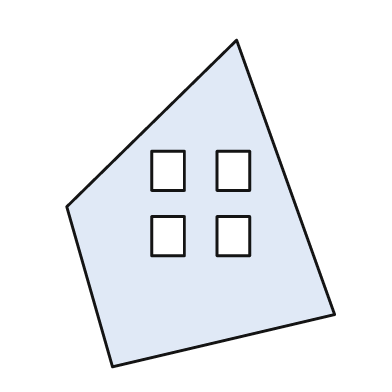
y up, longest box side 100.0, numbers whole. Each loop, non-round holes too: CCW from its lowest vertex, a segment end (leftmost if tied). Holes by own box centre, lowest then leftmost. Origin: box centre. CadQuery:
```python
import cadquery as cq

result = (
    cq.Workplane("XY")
    .moveTo(-27.0, -50.0)
    .lineTo(41.0, -34.0)
    .lineTo(11.0, 50.0)
    .lineTo(-41.0, -1.0)
    .close()
    .moveTo(-15.0, -16.0)
    .lineTo(-5.0, -16.0)
    .lineTo(-5.0, -4.0)
    .lineTo(-15.0, -4.0)
    .close()
    .moveTo(5.0, -16.0)
    .lineTo(15.0, -16.0)
    .lineTo(15.0, -4.0)
    .lineTo(5.0, -4.0)
    .close()
    .moveTo(-15.0, 4.0)
    .lineTo(-5.0, 4.0)
    .lineTo(-5.0, 16.0)
    .lineTo(-15.0, 16.0)
    .close()
    .moveTo(5.0, 4.0)
    .lineTo(15.0, 4.0)
    .lineTo(15.0, 16.0)
    .lineTo(5.0, 16.0)
    .close()
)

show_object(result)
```